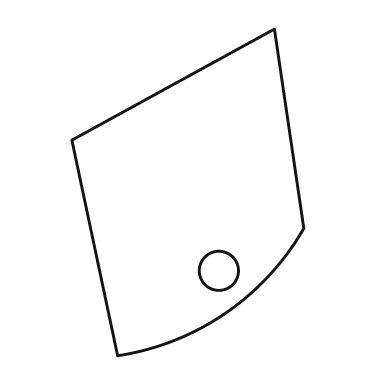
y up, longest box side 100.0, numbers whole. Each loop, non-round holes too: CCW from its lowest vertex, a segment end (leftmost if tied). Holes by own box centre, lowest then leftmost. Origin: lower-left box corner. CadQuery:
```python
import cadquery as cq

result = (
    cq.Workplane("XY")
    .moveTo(14.0, 0.0)
    .threePointArc((47.0, 13.0), (71.0, 39.0))
    .lineTo(62.0, 100.0)
    .lineTo(0.0, 66.0)
    .close()
    .moveTo(45.0, 26.0)
    .circle(6.0)
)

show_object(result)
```